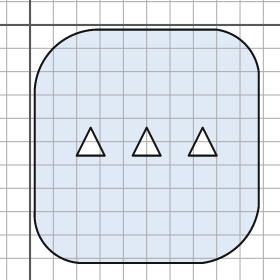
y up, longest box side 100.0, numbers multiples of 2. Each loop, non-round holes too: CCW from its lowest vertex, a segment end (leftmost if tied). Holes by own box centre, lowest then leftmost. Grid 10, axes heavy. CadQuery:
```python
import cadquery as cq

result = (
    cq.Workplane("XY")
    .moveTo(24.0, -102.0)
    .lineTo(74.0, -102.0)
    .threePointArc((90.0, -94.0), (98.0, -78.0))
    .lineTo(98.0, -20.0)
    .threePointArc((92.0, -8.0), (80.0, -2.0))
    .lineTo(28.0, -2.0)
    .threePointArc((10.0, -10.0), (2.0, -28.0))
    .lineTo(2.0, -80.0)
    .threePointArc((8.0, -96.0), (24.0, -102.0))
    .close()
    .moveTo(20.0, -56.0)
    .lineTo(32.0, -56.0)
    .lineTo(26.0, -44.0)
    .close()
    .moveTo(44.0, -56.0)
    .lineTo(56.0, -56.0)
    .lineTo(50.0, -44.0)
    .close()
    .moveTo(68.0, -56.0)
    .lineTo(80.0, -56.0)
    .lineTo(74.0, -44.0)
    .close()
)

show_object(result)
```